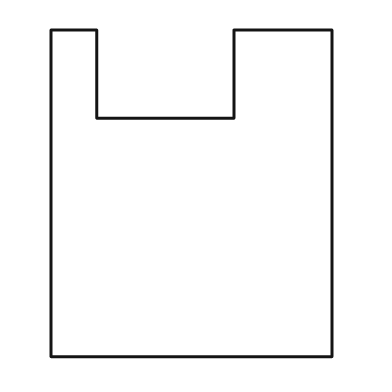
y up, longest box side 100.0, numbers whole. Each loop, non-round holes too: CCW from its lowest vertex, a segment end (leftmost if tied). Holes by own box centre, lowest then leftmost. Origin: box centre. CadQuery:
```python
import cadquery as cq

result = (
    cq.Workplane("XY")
    .moveTo(-43.0, -50.0)
    .lineTo(43.0, -50.0)
    .lineTo(43.0, 50.0)
    .lineTo(13.0, 50.0)
    .lineTo(13.0, 23.0)
    .lineTo(-29.0, 23.0)
    .lineTo(-29.0, 50.0)
    .lineTo(-43.0, 50.0)
    .close()
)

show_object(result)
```